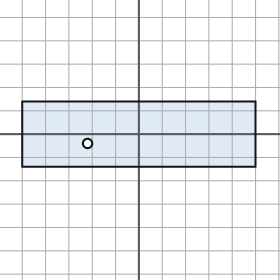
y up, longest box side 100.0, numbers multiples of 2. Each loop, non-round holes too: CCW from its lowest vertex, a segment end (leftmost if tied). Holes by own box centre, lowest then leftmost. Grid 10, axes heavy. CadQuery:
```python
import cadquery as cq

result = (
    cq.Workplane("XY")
    .moveTo(-50.0, -14.0)
    .lineTo(50.0, -14.0)
    .lineTo(50.0, 14.0)
    .lineTo(-50.0, 14.0)
    .close()
    .moveTo(-22.0, -4.0)
    .circle(2.0)
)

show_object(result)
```